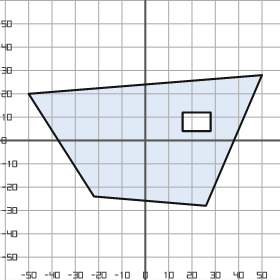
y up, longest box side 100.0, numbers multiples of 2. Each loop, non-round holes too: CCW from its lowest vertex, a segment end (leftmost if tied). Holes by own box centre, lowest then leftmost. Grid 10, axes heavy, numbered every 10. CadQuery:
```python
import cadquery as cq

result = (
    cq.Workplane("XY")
    .moveTo(26.0, -28.0)
    .lineTo(50.0, 28.0)
    .lineTo(-50.0, 20.0)
    .lineTo(-22.0, -24.0)
    .close()
    .moveTo(16.0, 4.0)
    .lineTo(28.0, 4.0)
    .lineTo(28.0, 12.0)
    .lineTo(16.0, 12.0)
    .close()
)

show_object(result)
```